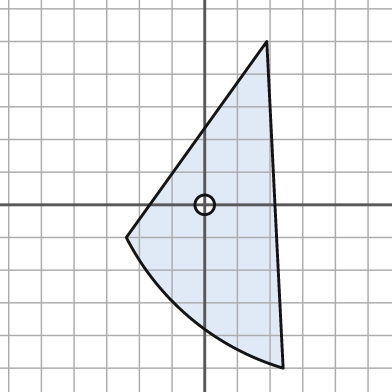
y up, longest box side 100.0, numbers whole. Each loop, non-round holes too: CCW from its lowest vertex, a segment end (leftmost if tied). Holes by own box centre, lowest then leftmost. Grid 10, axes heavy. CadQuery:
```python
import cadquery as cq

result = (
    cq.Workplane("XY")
    .moveTo(24.0, -50.0)
    .lineTo(19.0, 50.0)
    .lineTo(-24.0, -10.0)
    .threePointArc((-4.0, -35.0), (24.0, -50.0))
    .close()
    .moveTo(0.0, 0.0)
    .circle(3.0)
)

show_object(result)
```